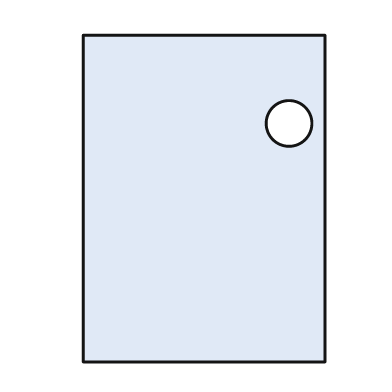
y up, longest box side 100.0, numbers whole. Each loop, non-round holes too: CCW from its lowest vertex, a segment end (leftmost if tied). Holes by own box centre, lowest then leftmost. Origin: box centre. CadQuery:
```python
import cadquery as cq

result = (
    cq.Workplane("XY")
    .moveTo(-37.0, -50.0)
    .lineTo(37.0, -50.0)
    .lineTo(37.0, 50.0)
    .lineTo(-37.0, 50.0)
    .close()
    .moveTo(26.0, 23.0)
    .circle(7.0)
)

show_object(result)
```